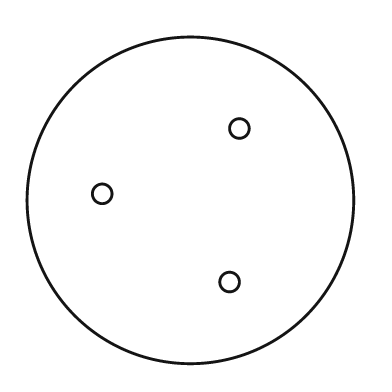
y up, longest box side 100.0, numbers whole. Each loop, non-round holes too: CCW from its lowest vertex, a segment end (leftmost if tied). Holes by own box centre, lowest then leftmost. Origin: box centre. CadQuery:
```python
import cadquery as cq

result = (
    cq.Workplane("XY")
    .moveTo(0.0, 0.0)
    .circle(50.0)
    .moveTo(12.0, -25.0)
    .circle(3.0)
    .moveTo(-27.0, 2.0)
    .circle(3.0)
    .moveTo(15.0, 22.0)
    .circle(3.0)
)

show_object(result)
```